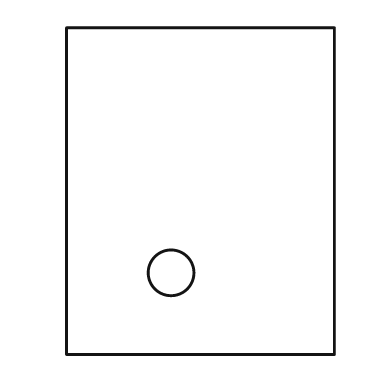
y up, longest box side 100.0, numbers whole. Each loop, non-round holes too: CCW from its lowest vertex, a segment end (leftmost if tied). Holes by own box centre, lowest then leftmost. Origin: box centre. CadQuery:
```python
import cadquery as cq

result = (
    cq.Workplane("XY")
    .moveTo(-41.0, -50.0)
    .lineTo(41.0, -50.0)
    .lineTo(41.0, 50.0)
    .lineTo(-41.0, 50.0)
    .close()
    .moveTo(-9.0, -25.0)
    .circle(7.0)
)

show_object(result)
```